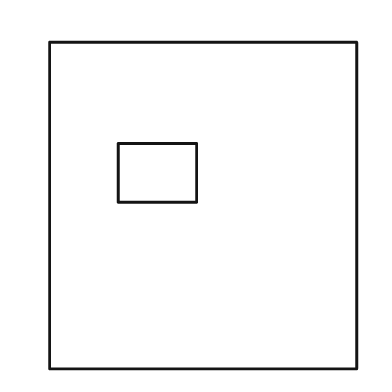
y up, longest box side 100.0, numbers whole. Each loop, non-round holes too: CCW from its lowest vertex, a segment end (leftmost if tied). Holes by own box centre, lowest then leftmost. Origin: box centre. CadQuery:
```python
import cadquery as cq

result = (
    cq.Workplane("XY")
    .moveTo(-47.0, -50.0)
    .lineTo(47.0, -50.0)
    .lineTo(47.0, 50.0)
    .lineTo(-47.0, 50.0)
    .close()
    .moveTo(-26.0, 1.0)
    .lineTo(-2.0, 1.0)
    .lineTo(-2.0, 19.0)
    .lineTo(-26.0, 19.0)
    .close()
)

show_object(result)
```